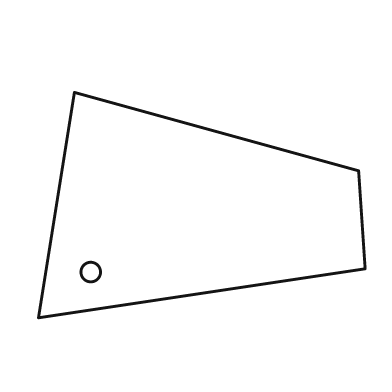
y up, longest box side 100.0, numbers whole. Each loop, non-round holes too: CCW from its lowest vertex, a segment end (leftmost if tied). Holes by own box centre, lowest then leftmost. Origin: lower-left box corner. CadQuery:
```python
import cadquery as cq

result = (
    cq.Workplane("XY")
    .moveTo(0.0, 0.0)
    .lineTo(100.0, 15.0)
    .lineTo(98.0, 45.0)
    .lineTo(11.0, 69.0)
    .close()
    .moveTo(16.0, 14.0)
    .circle(3.0)
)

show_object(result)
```